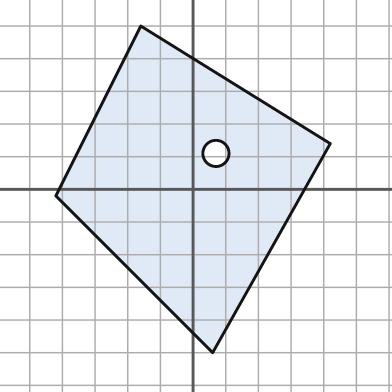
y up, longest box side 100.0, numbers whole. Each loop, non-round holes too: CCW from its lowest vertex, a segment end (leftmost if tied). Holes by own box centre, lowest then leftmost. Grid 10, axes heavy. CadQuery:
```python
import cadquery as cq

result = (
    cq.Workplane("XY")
    .moveTo(6.0, -50.0)
    .lineTo(42.0, 14.0)
    .lineTo(-16.0, 50.0)
    .lineTo(-42.0, -2.0)
    .close()
    .moveTo(7.0, 11.0)
    .circle(4.0)
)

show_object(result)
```